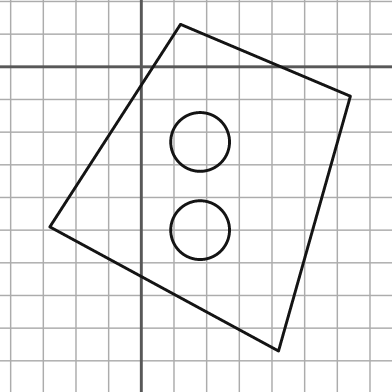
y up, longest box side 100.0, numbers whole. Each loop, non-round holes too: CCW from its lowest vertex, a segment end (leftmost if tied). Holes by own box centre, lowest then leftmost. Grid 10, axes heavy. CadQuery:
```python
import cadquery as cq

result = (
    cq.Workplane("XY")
    .moveTo(42.0, -87.0)
    .lineTo(64.0, -9.0)
    .lineTo(12.0, 13.0)
    .lineTo(-28.0, -49.0)
    .close()
    .moveTo(18.0, -50.0)
    .circle(9.0)
    .moveTo(18.0, -23.0)
    .circle(9.0)
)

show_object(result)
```